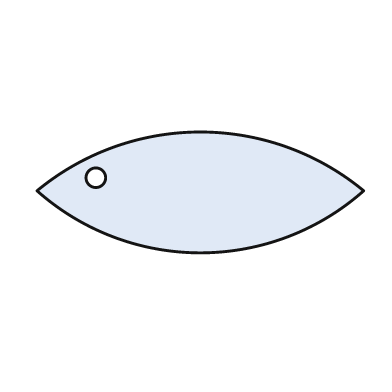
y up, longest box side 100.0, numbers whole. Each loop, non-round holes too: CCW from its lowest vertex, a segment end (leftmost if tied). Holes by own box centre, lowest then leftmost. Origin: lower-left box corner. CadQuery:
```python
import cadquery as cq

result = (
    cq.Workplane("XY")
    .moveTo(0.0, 19.0)
    .threePointArc((50.0, 0.0), (100.0, 19.0))
    .threePointArc((50.0, 37.0), (0.0, 19.0))
    .close()
    .moveTo(18.0, 23.0)
    .circle(3.0)
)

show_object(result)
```